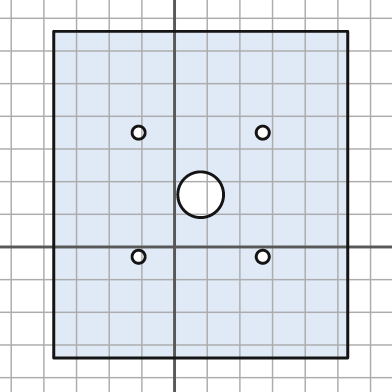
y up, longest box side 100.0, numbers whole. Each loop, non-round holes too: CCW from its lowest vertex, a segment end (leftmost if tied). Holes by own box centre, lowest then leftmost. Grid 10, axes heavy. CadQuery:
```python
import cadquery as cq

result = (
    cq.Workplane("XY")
    .moveTo(-37.0, -34.0)
    .lineTo(53.0, -34.0)
    .lineTo(53.0, 66.0)
    .lineTo(-37.0, 66.0)
    .close()
    .moveTo(-11.0, -3.0)
    .circle(2.0)
    .moveTo(27.0, -3.0)
    .circle(2.0)
    .moveTo(8.0, 16.0)
    .circle(7.0)
    .moveTo(-11.0, 35.0)
    .circle(2.0)
    .moveTo(27.0, 35.0)
    .circle(2.0)
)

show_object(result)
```